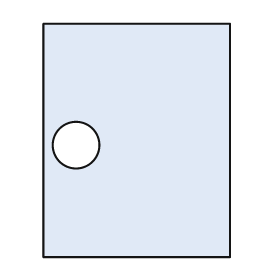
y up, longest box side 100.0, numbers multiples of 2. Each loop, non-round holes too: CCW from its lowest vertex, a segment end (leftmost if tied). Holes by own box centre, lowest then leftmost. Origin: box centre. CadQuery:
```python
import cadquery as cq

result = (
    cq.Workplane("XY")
    .moveTo(-40.0, -50.0)
    .lineTo(40.0, -50.0)
    .lineTo(40.0, 50.0)
    .lineTo(-40.0, 50.0)
    .close()
    .moveTo(-26.0, -2.0)
    .circle(10.0)
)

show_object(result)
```